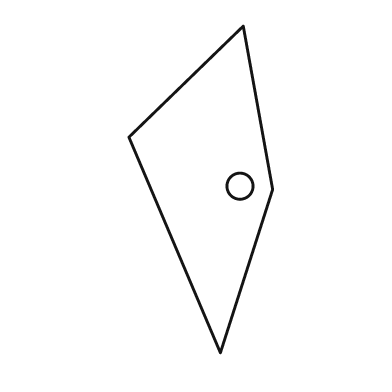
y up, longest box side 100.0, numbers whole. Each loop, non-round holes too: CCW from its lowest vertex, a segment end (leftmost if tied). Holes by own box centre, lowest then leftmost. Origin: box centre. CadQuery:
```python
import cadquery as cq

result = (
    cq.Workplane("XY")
    .moveTo(6.0, -50.0)
    .lineTo(22.0, 0.0)
    .lineTo(13.0, 50.0)
    .lineTo(-22.0, 16.0)
    .close()
    .moveTo(12.0, 1.0)
    .circle(4.0)
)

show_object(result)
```